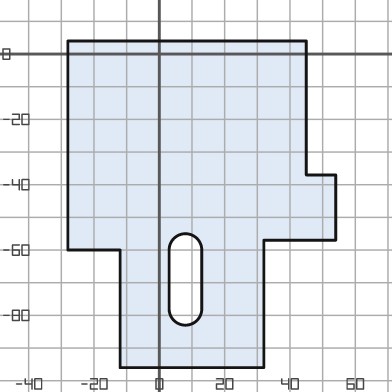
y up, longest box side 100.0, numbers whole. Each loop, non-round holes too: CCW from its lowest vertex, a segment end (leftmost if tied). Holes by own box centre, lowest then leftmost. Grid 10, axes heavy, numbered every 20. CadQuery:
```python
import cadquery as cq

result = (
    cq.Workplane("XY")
    .moveTo(-12.0, -96.0)
    .lineTo(32.0, -96.0)
    .lineTo(32.0, -57.0)
    .lineTo(54.0, -57.0)
    .lineTo(54.0, -37.0)
    .lineTo(45.0, -37.0)
    .lineTo(45.0, 4.0)
    .lineTo(-28.0, 4.0)
    .lineTo(-28.0, -60.0)
    .lineTo(-12.0, -60.0)
    .close()
    .moveTo(3.0, -78.0)
    .threePointArc((8.0, -83.0), (13.0, -78.0))
    .lineTo(13.0, -60.0)
    .threePointArc((8.0, -55.0), (3.0, -60.0))
    .close()
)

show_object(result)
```